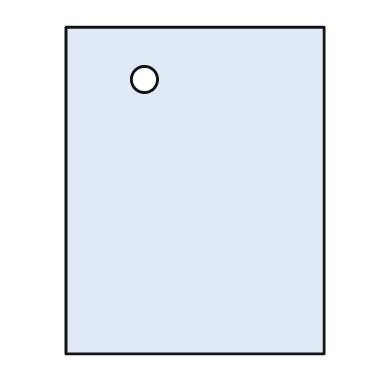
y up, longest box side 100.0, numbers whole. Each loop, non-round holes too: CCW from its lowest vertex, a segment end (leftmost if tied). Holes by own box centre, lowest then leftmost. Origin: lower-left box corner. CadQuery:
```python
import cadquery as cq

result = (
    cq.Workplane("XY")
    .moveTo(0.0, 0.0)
    .lineTo(79.0, 0.0)
    .lineTo(79.0, 100.0)
    .lineTo(0.0, 100.0)
    .close()
    .moveTo(24.0, 84.0)
    .circle(4.0)
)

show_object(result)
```